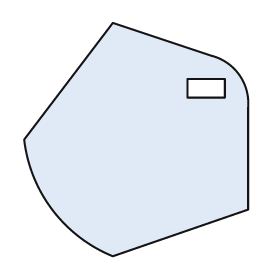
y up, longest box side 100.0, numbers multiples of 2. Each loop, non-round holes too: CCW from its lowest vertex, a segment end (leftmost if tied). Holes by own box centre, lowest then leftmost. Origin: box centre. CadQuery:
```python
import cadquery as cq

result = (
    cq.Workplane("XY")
    .moveTo(-10.0, -50.0)
    .lineTo(48.0, -30.0)
    .lineTo(48.0, 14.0)
    .threePointArc((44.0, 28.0), (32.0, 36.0))
    .lineTo(-10.0, 50.0)
    .lineTo(-48.0, 0.0)
    .threePointArc((-36.0, -30.0), (-10.0, -50.0))
    .close()
    .moveTo(22.0, 18.0)
    .lineTo(38.0, 18.0)
    .lineTo(38.0, 26.0)
    .lineTo(22.0, 26.0)
    .close()
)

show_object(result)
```